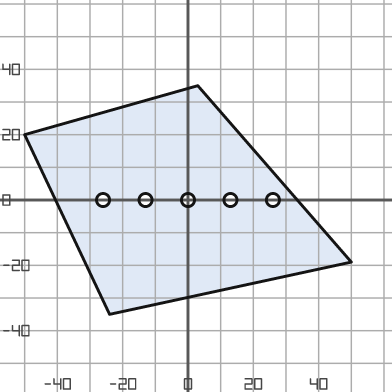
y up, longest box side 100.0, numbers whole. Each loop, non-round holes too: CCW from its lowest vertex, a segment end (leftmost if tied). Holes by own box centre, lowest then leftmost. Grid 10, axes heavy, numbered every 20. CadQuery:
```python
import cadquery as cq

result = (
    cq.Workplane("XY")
    .moveTo(-24.0, -35.0)
    .lineTo(50.0, -19.0)
    .lineTo(3.0, 35.0)
    .lineTo(-50.0, 20.0)
    .close()
    .moveTo(-26.0, 0.0)
    .circle(2.0)
    .moveTo(-13.0, 0.0)
    .circle(2.0)
    .moveTo(0.0, 0.0)
    .circle(2.0)
    .moveTo(13.0, 0.0)
    .circle(2.0)
    .moveTo(26.0, 0.0)
    .circle(2.0)
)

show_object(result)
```